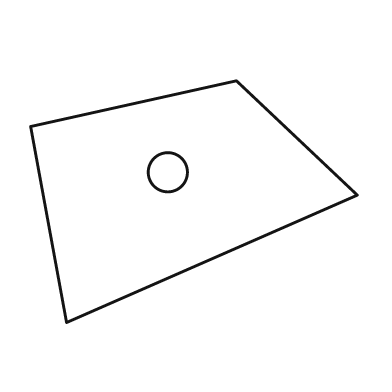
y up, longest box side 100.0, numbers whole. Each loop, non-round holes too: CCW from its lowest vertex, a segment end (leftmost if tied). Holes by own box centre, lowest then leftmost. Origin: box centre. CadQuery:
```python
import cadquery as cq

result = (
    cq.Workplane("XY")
    .moveTo(-39.0, -37.0)
    .lineTo(50.0, 2.0)
    .lineTo(13.0, 37.0)
    .lineTo(-50.0, 23.0)
    .close()
    .moveTo(-8.0, 9.0)
    .circle(6.0)
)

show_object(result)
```